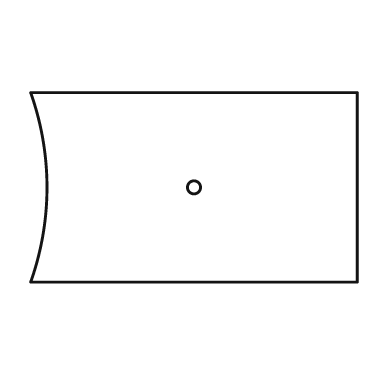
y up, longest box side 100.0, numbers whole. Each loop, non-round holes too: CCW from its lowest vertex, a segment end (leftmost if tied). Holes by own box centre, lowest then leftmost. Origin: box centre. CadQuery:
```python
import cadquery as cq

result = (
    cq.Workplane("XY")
    .moveTo(-50.0, -29.0)
    .lineTo(50.0, -29.0)
    .lineTo(50.0, 29.0)
    .lineTo(-50.0, 29.0)
    .threePointArc((-45.0, 0.0), (-50.0, -29.0))
    .close()
    .moveTo(0.0, 0.0)
    .circle(2.0)
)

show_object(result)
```